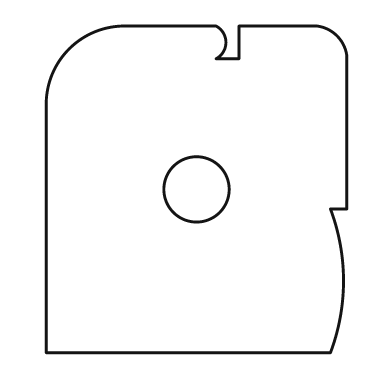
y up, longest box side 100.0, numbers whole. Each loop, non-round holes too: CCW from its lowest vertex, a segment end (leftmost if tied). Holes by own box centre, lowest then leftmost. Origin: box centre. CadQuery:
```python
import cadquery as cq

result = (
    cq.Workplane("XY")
    .moveTo(-46.0, -50.0)
    .lineTo(41.0, -50.0)
    .threePointArc((45.0, -28.0), (41.0, -6.0))
    .lineTo(46.0, -6.0)
    .lineTo(46.0, 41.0)
    .threePointArc((43.0, 47.0), (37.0, 50.0))
    .lineTo(13.0, 50.0)
    .lineTo(13.0, 40.0)
    .lineTo(6.0, 40.0)
    .threePointArc((9.0, 45.0), (6.0, 50.0))
    .lineTo(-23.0, 50.0)
    .threePointArc((-39.0, 43.0), (-46.0, 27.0))
    .close()
    .moveTo(0.0, 0.0)
    .circle(10.0)
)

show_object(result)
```